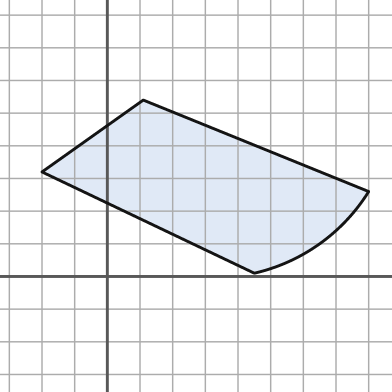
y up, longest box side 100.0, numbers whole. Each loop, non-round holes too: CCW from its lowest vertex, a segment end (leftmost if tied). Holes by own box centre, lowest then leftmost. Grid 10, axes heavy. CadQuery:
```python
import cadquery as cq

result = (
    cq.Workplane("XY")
    .moveTo(45.0, 1.0)
    .threePointArc((65.0, 10.0), (80.0, 26.0))
    .lineTo(11.0, 54.0)
    .lineTo(-20.0, 32.0)
    .close()
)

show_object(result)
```